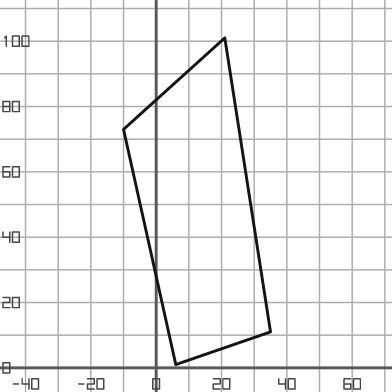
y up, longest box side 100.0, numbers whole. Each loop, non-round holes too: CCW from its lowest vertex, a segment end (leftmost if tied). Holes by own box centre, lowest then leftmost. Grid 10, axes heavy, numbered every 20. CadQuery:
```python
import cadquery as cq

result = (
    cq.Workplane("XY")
    .moveTo(6.0, 1.0)
    .lineTo(35.0, 11.0)
    .lineTo(21.0, 101.0)
    .lineTo(-10.0, 73.0)
    .close()
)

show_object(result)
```